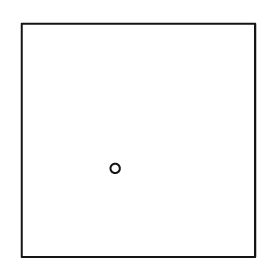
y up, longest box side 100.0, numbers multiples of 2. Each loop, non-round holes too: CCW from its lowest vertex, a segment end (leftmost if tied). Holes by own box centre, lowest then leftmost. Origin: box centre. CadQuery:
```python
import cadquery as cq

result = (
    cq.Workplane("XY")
    .moveTo(-50.0, -50.0)
    .lineTo(50.0, -50.0)
    .lineTo(50.0, 50.0)
    .lineTo(-50.0, 50.0)
    .close()
    .moveTo(-10.0, -12.0)
    .circle(2.0)
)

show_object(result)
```